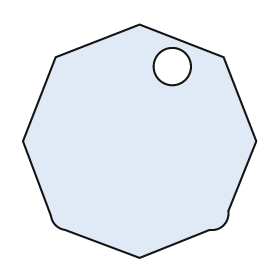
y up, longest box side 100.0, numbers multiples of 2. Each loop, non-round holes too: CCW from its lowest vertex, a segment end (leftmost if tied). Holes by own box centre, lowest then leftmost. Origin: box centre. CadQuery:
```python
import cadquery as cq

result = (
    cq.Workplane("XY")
    .moveTo(0.0, -50.0)
    .lineTo(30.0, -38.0)
    .threePointArc((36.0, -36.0), (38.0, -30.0))
    .lineTo(50.0, 0.0)
    .lineTo(36.0, 36.0)
    .lineTo(0.0, 50.0)
    .lineTo(-36.0, 36.0)
    .lineTo(-50.0, 0.0)
    .lineTo(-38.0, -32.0)
    .threePointArc((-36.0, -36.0), (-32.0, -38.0))
    .close()
    .moveTo(14.0, 32.0)
    .circle(8.0)
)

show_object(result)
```